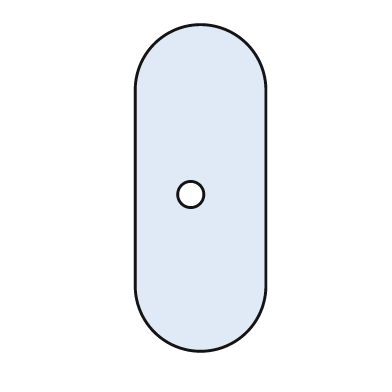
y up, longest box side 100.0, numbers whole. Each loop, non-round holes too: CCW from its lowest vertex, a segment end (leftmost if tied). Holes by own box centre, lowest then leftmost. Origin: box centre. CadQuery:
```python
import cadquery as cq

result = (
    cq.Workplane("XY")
    .moveTo(-20.0, -30.0)
    .threePointArc((0.0, -50.0), (20.0, -30.0))
    .lineTo(20.0, 30.0)
    .threePointArc((0.0, 50.0), (-20.0, 30.0))
    .close()
    .moveTo(-3.0, -2.0)
    .circle(4.0)
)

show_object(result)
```